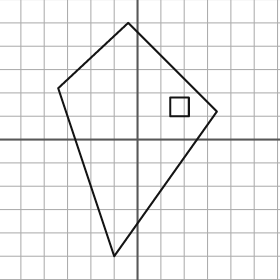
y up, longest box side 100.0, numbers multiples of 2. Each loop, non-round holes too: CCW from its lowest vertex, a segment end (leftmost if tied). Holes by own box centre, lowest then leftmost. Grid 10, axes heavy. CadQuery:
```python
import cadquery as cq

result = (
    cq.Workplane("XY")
    .moveTo(-10.0, -50.0)
    .lineTo(34.0, 12.0)
    .lineTo(-4.0, 50.0)
    .lineTo(-34.0, 22.0)
    .close()
    .moveTo(14.0, 10.0)
    .lineTo(22.0, 10.0)
    .lineTo(22.0, 18.0)
    .lineTo(14.0, 18.0)
    .close()
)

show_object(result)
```